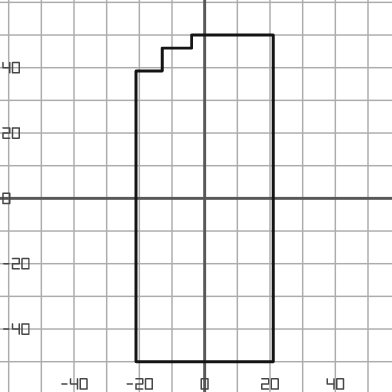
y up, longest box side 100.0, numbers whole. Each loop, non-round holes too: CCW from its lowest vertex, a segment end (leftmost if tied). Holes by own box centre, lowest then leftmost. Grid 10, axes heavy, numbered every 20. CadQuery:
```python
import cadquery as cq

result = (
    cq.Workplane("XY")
    .moveTo(-21.0, -50.0)
    .lineTo(21.0, -50.0)
    .lineTo(21.0, 50.0)
    .lineTo(-4.0, 50.0)
    .lineTo(-4.0, 46.0)
    .lineTo(-13.0, 46.0)
    .lineTo(-13.0, 39.0)
    .lineTo(-21.0, 39.0)
    .close()
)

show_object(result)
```